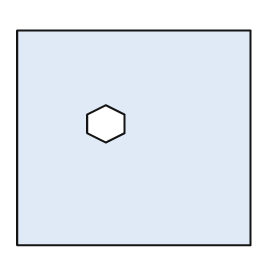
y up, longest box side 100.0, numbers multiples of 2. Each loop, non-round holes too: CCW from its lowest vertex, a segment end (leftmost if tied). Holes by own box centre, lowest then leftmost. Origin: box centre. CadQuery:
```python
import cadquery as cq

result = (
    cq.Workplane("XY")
    .moveTo(-50.0, -46.0)
    .lineTo(50.0, -46.0)
    .lineTo(50.0, 46.0)
    .lineTo(-50.0, 46.0)
    .close()
    .moveTo(-12.0, -2.0)
    .lineTo(-4.0, 2.0)
    .lineTo(-4.0, 10.0)
    .lineTo(-12.0, 14.0)
    .lineTo(-20.0, 10.0)
    .lineTo(-20.0, 2.0)
    .close()
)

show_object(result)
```